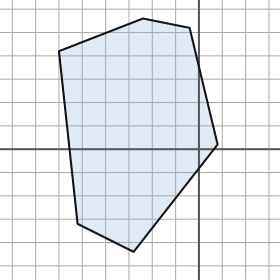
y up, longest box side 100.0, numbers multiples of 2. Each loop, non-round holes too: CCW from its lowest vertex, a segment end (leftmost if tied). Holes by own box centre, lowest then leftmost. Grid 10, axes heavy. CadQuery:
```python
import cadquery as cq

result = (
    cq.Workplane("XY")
    .moveTo(-28.0, -44.0)
    .lineTo(8.0, 2.0)
    .lineTo(-4.0, 52.0)
    .lineTo(-24.0, 56.0)
    .lineTo(-60.0, 42.0)
    .lineTo(-52.0, -32.0)
    .close()
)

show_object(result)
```